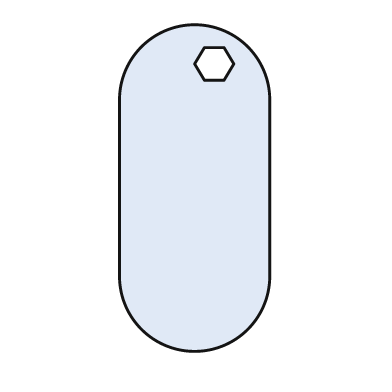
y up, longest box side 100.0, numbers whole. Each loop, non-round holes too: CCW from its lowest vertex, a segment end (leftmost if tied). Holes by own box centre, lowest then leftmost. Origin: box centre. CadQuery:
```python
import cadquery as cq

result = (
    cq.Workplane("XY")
    .moveTo(-23.0, -27.0)
    .threePointArc((0.0, -50.0), (23.0, -27.0))
    .lineTo(23.0, 27.0)
    .threePointArc((0.0, 50.0), (-23.0, 27.0))
    .close()
    .moveTo(3.0, 33.0)
    .lineTo(9.0, 33.0)
    .lineTo(12.0, 38.0)
    .lineTo(9.0, 43.0)
    .lineTo(3.0, 43.0)
    .lineTo(0.0, 38.0)
    .close()
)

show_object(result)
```